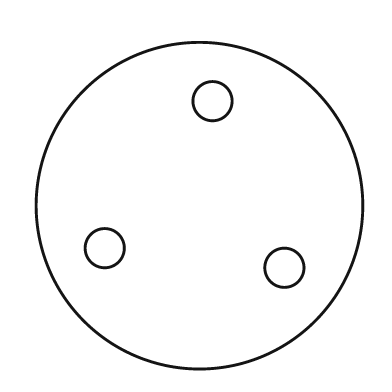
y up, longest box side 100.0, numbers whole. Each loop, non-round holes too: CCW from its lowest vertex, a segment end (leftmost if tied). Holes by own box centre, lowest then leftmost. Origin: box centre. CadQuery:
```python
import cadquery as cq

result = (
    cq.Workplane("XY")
    .moveTo(0.0, 0.0)
    .circle(50.0)
    .moveTo(26.0, -19.0)
    .circle(6.0)
    .moveTo(-29.0, -13.0)
    .circle(6.0)
    .moveTo(4.0, 32.0)
    .circle(6.0)
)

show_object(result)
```